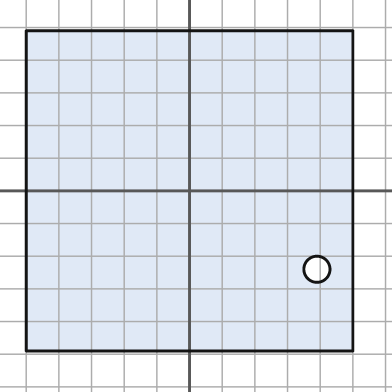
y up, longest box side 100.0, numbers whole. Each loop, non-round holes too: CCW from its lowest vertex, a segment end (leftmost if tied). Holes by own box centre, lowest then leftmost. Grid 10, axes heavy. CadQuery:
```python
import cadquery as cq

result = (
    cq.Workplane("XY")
    .moveTo(-50.0, -49.0)
    .lineTo(50.0, -49.0)
    .lineTo(50.0, 49.0)
    .lineTo(-50.0, 49.0)
    .close()
    .moveTo(39.0, -24.0)
    .circle(4.0)
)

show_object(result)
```